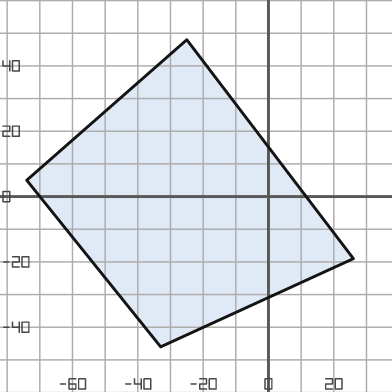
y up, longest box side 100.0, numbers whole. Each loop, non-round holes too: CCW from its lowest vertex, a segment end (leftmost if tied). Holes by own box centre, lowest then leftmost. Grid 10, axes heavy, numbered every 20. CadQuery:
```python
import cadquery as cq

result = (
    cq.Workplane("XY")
    .moveTo(-33.0, -46.0)
    .lineTo(26.0, -19.0)
    .lineTo(-25.0, 48.0)
    .lineTo(-74.0, 5.0)
    .close()
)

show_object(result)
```